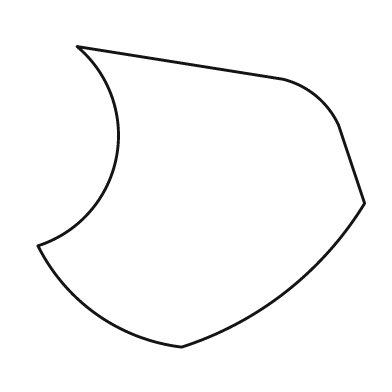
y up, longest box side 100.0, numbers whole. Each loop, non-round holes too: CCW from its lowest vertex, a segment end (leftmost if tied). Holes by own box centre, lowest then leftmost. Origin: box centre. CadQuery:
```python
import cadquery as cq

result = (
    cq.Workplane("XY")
    .moveTo(-6.0, -46.0)
    .threePointArc((26.0, -29.0), (50.0, -2.0))
    .lineTo(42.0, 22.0)
    .threePointArc((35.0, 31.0), (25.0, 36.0))
    .lineTo(-38.0, 46.0)
    .threePointArc((-26.0, 12.0), (-50.0, -15.0))
    .threePointArc((-32.0, -36.0), (-6.0, -46.0))
    .close()
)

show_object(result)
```